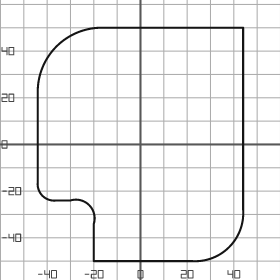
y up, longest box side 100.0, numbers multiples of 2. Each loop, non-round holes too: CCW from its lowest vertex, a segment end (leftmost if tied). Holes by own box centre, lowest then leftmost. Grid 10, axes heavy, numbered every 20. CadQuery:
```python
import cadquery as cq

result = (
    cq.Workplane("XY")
    .moveTo(-20.0, -50.0)
    .lineTo(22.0, -50.0)
    .threePointArc((38.0, -44.0), (44.0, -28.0))
    .lineTo(44.0, 50.0)
    .lineTo(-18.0, 50.0)
    .threePointArc((-36.0, 42.0), (-44.0, 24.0))
    .lineTo(-44.0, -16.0)
    .threePointArc((-42.0, -22.0), (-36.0, -24.0))
    .lineTo(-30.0, -24.0)
    .threePointArc((-22.0, -26.0), (-20.0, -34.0))
    .close()
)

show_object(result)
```